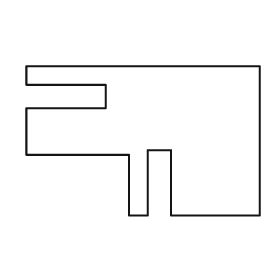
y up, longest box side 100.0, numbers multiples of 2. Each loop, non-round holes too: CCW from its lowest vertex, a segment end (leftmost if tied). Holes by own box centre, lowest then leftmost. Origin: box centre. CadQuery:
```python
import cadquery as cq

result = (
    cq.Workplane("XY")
    .moveTo(-6.0, -32.0)
    .lineTo(2.0, -32.0)
    .lineTo(2.0, -4.0)
    .lineTo(12.0, -4.0)
    .lineTo(12.0, -32.0)
    .lineTo(50.0, -32.0)
    .lineTo(50.0, 32.0)
    .lineTo(-50.0, 32.0)
    .lineTo(-50.0, 24.0)
    .lineTo(-16.0, 24.0)
    .lineTo(-16.0, 14.0)
    .lineTo(-50.0, 14.0)
    .lineTo(-50.0, -6.0)
    .lineTo(-6.0, -6.0)
    .close()
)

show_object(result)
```